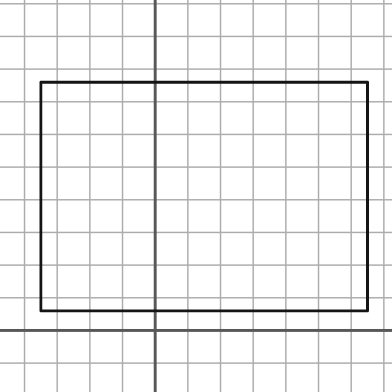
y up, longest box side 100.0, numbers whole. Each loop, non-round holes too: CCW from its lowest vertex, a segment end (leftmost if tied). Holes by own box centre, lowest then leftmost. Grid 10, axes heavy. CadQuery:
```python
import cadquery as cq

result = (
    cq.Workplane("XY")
    .moveTo(-35.0, 6.0)
    .lineTo(65.0, 6.0)
    .lineTo(65.0, 76.0)
    .lineTo(-35.0, 76.0)
    .close()
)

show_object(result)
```